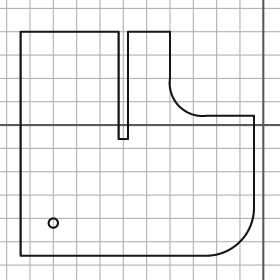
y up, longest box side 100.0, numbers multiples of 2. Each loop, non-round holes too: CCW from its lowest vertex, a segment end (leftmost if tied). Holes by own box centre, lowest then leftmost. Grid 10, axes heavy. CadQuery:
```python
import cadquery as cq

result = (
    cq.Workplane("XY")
    .moveTo(-104.0, -56.0)
    .lineTo(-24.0, -56.0)
    .threePointArc((-10.0, -50.0), (-4.0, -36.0))
    .lineTo(-4.0, 4.0)
    .lineTo(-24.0, 4.0)
    .threePointArc((-36.0, 8.0), (-40.0, 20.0))
    .lineTo(-40.0, 40.0)
    .lineTo(-58.0, 40.0)
    .lineTo(-58.0, -6.0)
    .lineTo(-62.0, -6.0)
    .lineTo(-62.0, 40.0)
    .lineTo(-104.0, 40.0)
    .close()
    .moveTo(-90.0, -42.0)
    .circle(2.0)
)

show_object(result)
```